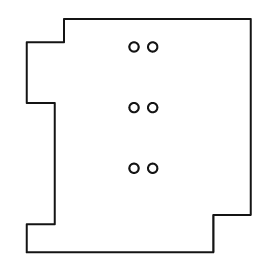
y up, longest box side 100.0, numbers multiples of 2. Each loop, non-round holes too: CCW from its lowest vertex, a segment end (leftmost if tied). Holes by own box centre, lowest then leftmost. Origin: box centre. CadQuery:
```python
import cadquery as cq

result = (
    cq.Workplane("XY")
    .moveTo(-48.0, -50.0)
    .lineTo(32.0, -50.0)
    .lineTo(32.0, -34.0)
    .lineTo(48.0, -34.0)
    .lineTo(48.0, 50.0)
    .lineTo(-32.0, 50.0)
    .lineTo(-32.0, 40.0)
    .lineTo(-48.0, 40.0)
    .lineTo(-48.0, 14.0)
    .lineTo(-36.0, 14.0)
    .lineTo(-36.0, -38.0)
    .lineTo(-48.0, -38.0)
    .close()
    .moveTo(-2.0, -14.0)
    .circle(2.0)
    .moveTo(6.0, -14.0)
    .circle(2.0)
    .moveTo(-2.0, 12.0)
    .circle(2.0)
    .moveTo(6.0, 12.0)
    .circle(2.0)
    .moveTo(-2.0, 38.0)
    .circle(2.0)
    .moveTo(6.0, 38.0)
    .circle(2.0)
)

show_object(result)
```